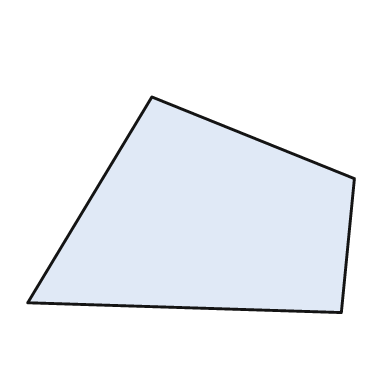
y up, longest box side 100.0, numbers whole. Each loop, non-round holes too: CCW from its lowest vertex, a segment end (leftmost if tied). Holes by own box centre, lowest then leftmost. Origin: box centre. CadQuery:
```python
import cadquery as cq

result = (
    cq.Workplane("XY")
    .moveTo(46.0, -33.0)
    .lineTo(50.0, 8.0)
    .lineTo(-12.0, 33.0)
    .lineTo(-50.0, -30.0)
    .close()
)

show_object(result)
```